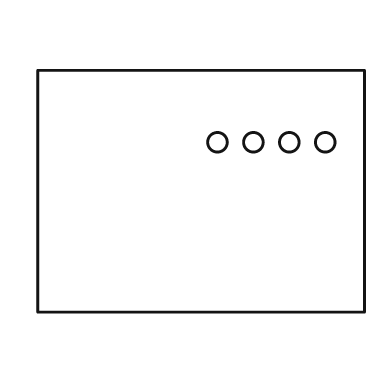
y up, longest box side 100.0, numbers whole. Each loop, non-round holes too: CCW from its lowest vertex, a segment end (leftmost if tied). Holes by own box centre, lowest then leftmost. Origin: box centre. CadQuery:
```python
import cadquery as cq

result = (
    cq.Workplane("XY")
    .moveTo(-50.0, -37.0)
    .lineTo(50.0, -37.0)
    .lineTo(50.0, 37.0)
    .lineTo(-50.0, 37.0)
    .close()
    .moveTo(5.0, 15.0)
    .circle(3.0)
    .moveTo(16.0, 15.0)
    .circle(3.0)
    .moveTo(27.0, 15.0)
    .circle(3.0)
    .moveTo(38.0, 15.0)
    .circle(3.0)
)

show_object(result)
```